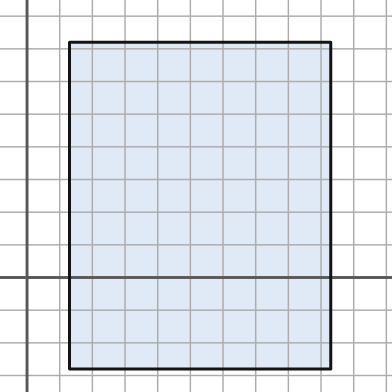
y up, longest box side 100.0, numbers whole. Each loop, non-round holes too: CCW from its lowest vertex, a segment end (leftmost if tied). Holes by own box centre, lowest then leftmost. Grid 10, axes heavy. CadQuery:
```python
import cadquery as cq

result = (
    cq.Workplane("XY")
    .moveTo(13.0, -28.0)
    .lineTo(93.0, -28.0)
    .lineTo(93.0, 72.0)
    .lineTo(13.0, 72.0)
    .close()
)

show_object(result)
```